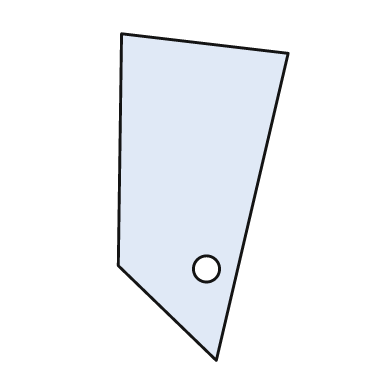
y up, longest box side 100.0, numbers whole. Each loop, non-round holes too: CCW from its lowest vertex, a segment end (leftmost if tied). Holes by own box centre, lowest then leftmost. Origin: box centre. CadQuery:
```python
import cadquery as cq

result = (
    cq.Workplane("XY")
    .moveTo(4.0, -50.0)
    .lineTo(26.0, 44.0)
    .lineTo(-25.0, 50.0)
    .lineTo(-26.0, -21.0)
    .close()
    .moveTo(1.0, -22.0)
    .circle(4.0)
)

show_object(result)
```